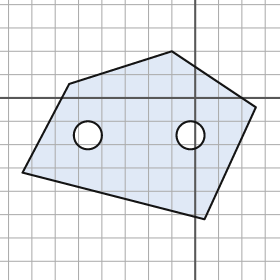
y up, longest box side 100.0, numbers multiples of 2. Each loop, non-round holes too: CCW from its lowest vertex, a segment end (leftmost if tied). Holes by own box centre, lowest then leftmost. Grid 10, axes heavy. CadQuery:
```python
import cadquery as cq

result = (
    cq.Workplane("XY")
    .moveTo(4.0, -52.0)
    .lineTo(26.0, -4.0)
    .lineTo(-10.0, 20.0)
    .lineTo(-54.0, 6.0)
    .lineTo(-74.0, -32.0)
    .close()
    .moveTo(-46.0, -16.0)
    .circle(6.0)
    .moveTo(-2.0, -16.0)
    .circle(6.0)
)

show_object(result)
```